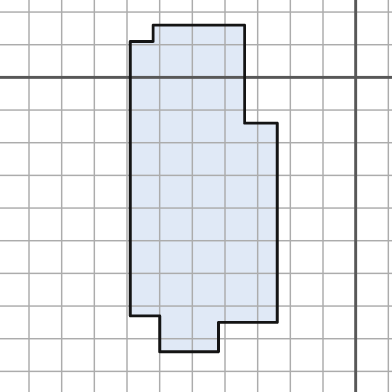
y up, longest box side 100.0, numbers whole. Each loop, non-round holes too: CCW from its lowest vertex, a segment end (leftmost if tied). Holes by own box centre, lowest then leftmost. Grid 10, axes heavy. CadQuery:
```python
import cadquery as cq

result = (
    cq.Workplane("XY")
    .moveTo(-60.0, -84.0)
    .lineTo(-42.0, -84.0)
    .lineTo(-42.0, -75.0)
    .lineTo(-24.0, -75.0)
    .lineTo(-24.0, -14.0)
    .lineTo(-34.0, -14.0)
    .lineTo(-34.0, 16.0)
    .lineTo(-62.0, 16.0)
    .lineTo(-62.0, 11.0)
    .lineTo(-69.0, 11.0)
    .lineTo(-69.0, -73.0)
    .lineTo(-60.0, -73.0)
    .close()
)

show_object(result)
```